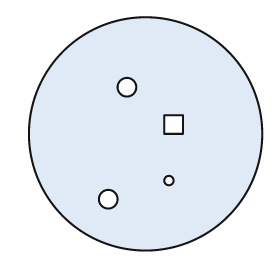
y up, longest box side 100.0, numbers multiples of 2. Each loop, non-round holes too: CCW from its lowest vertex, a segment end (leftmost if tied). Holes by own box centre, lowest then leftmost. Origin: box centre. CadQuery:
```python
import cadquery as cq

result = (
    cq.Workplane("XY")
    .moveTo(0.0, 0.0)
    .circle(50.0)
    .moveTo(-16.0, -28.0)
    .circle(4.0)
    .moveTo(10.0, -20.0)
    .circle(2.0)
    .moveTo(8.0, 0.0)
    .lineTo(16.0, 0.0)
    .lineTo(16.0, 8.0)
    .lineTo(8.0, 8.0)
    .close()
    .moveTo(-8.0, 20.0)
    .circle(4.0)
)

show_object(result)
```